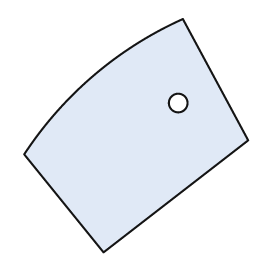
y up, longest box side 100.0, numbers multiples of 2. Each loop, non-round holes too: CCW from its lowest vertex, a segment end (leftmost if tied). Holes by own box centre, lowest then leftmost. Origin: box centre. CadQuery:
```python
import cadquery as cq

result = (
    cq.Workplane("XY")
    .moveTo(-14.0, -50.0)
    .lineTo(48.0, -2.0)
    .lineTo(20.0, 50.0)
    .threePointArc((-18.0, 26.0), (-48.0, -8.0))
    .close()
    .moveTo(18.0, 14.0)
    .circle(4.0)
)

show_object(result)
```